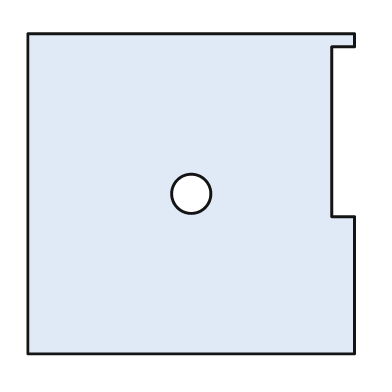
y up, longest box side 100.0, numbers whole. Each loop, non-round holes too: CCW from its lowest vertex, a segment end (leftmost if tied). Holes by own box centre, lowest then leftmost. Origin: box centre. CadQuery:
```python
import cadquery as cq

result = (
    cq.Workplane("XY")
    .moveTo(-50.0, -49.0)
    .lineTo(50.0, -49.0)
    .lineTo(50.0, -7.0)
    .lineTo(43.0, -7.0)
    .lineTo(43.0, 45.0)
    .lineTo(50.0, 45.0)
    .lineTo(50.0, 49.0)
    .lineTo(-50.0, 49.0)
    .close()
    .moveTo(0.0, 0.0)
    .circle(6.0)
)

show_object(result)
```